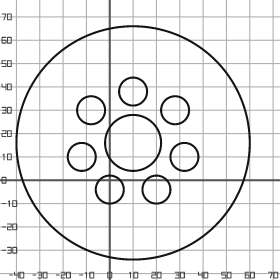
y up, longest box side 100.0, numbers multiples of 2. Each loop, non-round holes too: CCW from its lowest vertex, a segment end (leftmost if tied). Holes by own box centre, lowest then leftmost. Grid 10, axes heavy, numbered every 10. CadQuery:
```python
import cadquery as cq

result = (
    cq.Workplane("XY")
    .moveTo(10.0, 16.0)
    .circle(50.0)
    .moveTo(0.0, -4.0)
    .circle(6.0)
    .moveTo(20.0, -4.0)
    .circle(6.0)
    .moveTo(-12.0, 10.0)
    .circle(6.0)
    .moveTo(32.0, 10.0)
    .circle(6.0)
    .moveTo(10.0, 16.0)
    .circle(12.0)
    .moveTo(-8.0, 30.0)
    .circle(6.0)
    .moveTo(28.0, 30.0)
    .circle(6.0)
    .moveTo(10.0, 38.0)
    .circle(6.0)
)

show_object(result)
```